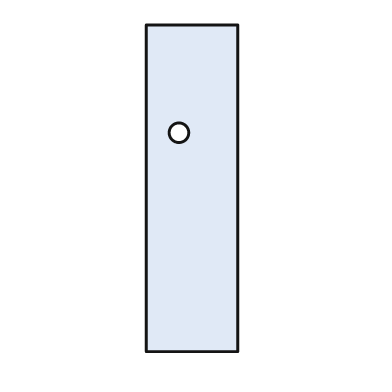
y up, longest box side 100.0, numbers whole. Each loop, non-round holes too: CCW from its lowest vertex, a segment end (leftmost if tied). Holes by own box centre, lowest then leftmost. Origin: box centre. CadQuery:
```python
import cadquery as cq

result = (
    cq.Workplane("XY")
    .moveTo(-14.0, -50.0)
    .lineTo(14.0, -50.0)
    .lineTo(14.0, 50.0)
    .lineTo(-14.0, 50.0)
    .close()
    .moveTo(-4.0, 17.0)
    .circle(3.0)
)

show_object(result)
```